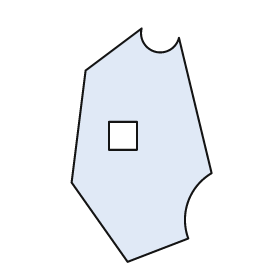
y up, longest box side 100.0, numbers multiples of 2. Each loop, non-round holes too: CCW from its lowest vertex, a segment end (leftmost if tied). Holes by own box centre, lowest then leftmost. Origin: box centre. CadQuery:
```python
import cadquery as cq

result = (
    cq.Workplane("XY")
    .moveTo(-6.0, -50.0)
    .lineTo(20.0, -40.0)
    .threePointArc((20.0, -24.0), (30.0, -12.0))
    .lineTo(16.0, 46.0)
    .threePointArc((6.0, 40.0), (0.0, 50.0))
    .lineTo(-24.0, 32.0)
    .lineTo(-30.0, -16.0)
    .close()
    .moveTo(-14.0, -2.0)
    .lineTo(-2.0, -2.0)
    .lineTo(-2.0, 10.0)
    .lineTo(-14.0, 10.0)
    .close()
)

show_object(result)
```